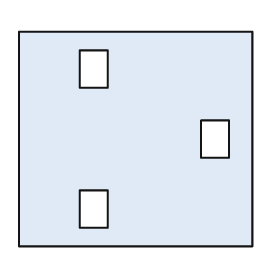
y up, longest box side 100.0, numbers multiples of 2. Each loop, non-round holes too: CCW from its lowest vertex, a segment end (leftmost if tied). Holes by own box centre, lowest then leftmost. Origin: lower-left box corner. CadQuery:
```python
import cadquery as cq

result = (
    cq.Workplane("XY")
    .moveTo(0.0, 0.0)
    .lineTo(100.0, 0.0)
    .lineTo(100.0, 92.0)
    .lineTo(0.0, 92.0)
    .close()
    .moveTo(26.0, 8.0)
    .lineTo(38.0, 8.0)
    .lineTo(38.0, 24.0)
    .lineTo(26.0, 24.0)
    .close()
    .moveTo(78.0, 38.0)
    .lineTo(90.0, 38.0)
    .lineTo(90.0, 54.0)
    .lineTo(78.0, 54.0)
    .close()
    .moveTo(26.0, 68.0)
    .lineTo(38.0, 68.0)
    .lineTo(38.0, 84.0)
    .lineTo(26.0, 84.0)
    .close()
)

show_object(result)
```